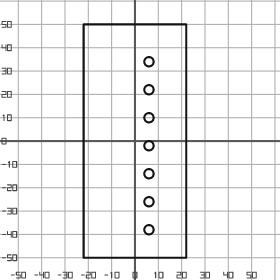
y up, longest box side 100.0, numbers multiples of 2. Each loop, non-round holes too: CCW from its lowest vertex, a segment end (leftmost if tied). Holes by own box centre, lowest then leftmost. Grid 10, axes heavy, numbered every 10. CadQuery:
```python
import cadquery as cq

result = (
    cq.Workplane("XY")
    .moveTo(-22.0, -50.0)
    .lineTo(22.0, -50.0)
    .lineTo(22.0, 50.0)
    .lineTo(-22.0, 50.0)
    .close()
    .moveTo(6.0, -38.0)
    .circle(2.0)
    .moveTo(6.0, -26.0)
    .circle(2.0)
    .moveTo(6.0, -14.0)
    .circle(2.0)
    .moveTo(6.0, -2.0)
    .circle(2.0)
    .moveTo(6.0, 10.0)
    .circle(2.0)
    .moveTo(6.0, 22.0)
    .circle(2.0)
    .moveTo(6.0, 34.0)
    .circle(2.0)
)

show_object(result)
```